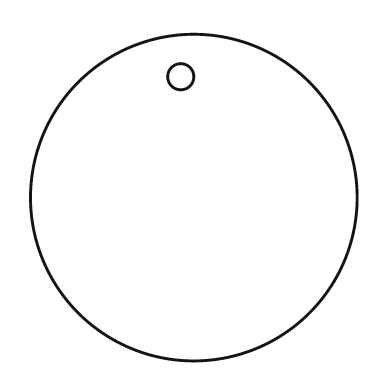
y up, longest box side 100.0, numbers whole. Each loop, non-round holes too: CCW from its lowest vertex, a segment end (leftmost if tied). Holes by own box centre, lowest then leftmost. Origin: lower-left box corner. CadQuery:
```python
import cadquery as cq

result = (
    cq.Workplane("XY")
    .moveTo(50.0, 50.0)
    .circle(50.0)
    .moveTo(46.0, 87.0)
    .circle(4.0)
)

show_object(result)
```